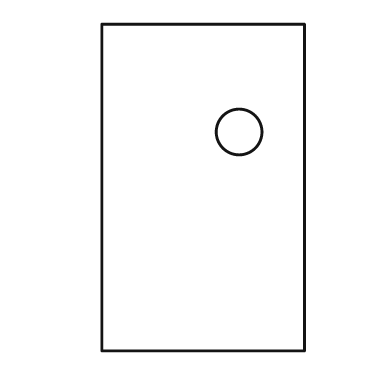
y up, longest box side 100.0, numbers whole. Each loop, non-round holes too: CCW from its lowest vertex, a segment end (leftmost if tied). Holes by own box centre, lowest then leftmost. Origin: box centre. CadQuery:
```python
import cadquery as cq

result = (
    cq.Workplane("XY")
    .moveTo(-31.0, -50.0)
    .lineTo(31.0, -50.0)
    .lineTo(31.0, 50.0)
    .lineTo(-31.0, 50.0)
    .close()
    .moveTo(11.0, 17.0)
    .circle(7.0)
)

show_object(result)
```